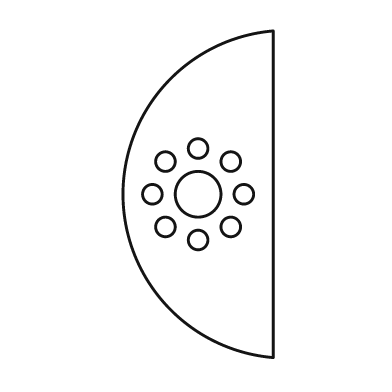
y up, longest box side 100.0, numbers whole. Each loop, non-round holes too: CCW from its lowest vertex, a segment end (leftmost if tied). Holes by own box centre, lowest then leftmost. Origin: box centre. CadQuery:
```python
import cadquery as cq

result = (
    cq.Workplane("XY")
    .moveTo(23.0, -50.0)
    .lineTo(23.0, 50.0)
    .threePointArc((-23.0, 0.0), (23.0, -50.0))
    .close()
    .moveTo(0.0, -14.0)
    .circle(3.0)
    .moveTo(-10.0, -10.0)
    .circle(3.0)
    .moveTo(10.0, -10.0)
    .circle(3.0)
    .moveTo(-14.0, 0.0)
    .circle(3.0)
    .moveTo(0.0, 0.0)
    .circle(7.0)
    .moveTo(14.0, 0.0)
    .circle(3.0)
    .moveTo(-10.0, 10.0)
    .circle(3.0)
    .moveTo(10.0, 10.0)
    .circle(3.0)
    .moveTo(0.0, 14.0)
    .circle(3.0)
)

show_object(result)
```